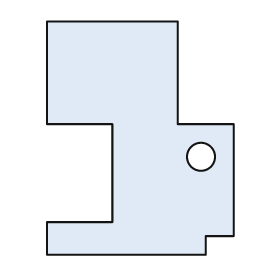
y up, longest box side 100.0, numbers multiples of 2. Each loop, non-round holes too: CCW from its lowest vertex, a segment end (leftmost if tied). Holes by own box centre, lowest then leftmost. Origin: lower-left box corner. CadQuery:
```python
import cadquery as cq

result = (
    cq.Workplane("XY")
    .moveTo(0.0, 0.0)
    .lineTo(68.0, 0.0)
    .lineTo(68.0, 8.0)
    .lineTo(80.0, 8.0)
    .lineTo(80.0, 56.0)
    .lineTo(56.0, 56.0)
    .lineTo(56.0, 100.0)
    .lineTo(0.0, 100.0)
    .lineTo(0.0, 56.0)
    .lineTo(28.0, 56.0)
    .lineTo(28.0, 14.0)
    .lineTo(0.0, 14.0)
    .close()
    .moveTo(66.0, 42.0)
    .circle(6.0)
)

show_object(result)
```